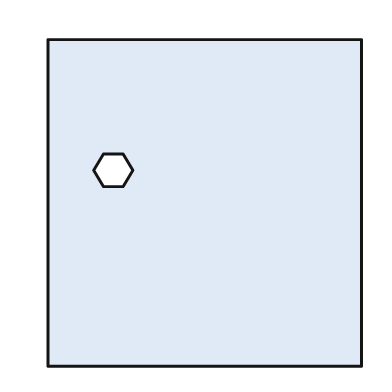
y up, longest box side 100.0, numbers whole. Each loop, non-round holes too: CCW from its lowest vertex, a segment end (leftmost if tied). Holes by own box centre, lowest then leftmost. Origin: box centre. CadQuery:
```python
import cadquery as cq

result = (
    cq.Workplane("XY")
    .moveTo(-48.0, -50.0)
    .lineTo(48.0, -50.0)
    .lineTo(48.0, 50.0)
    .lineTo(-48.0, 50.0)
    .close()
    .moveTo(-31.0, 5.0)
    .lineTo(-25.0, 5.0)
    .lineTo(-22.0, 10.0)
    .lineTo(-25.0, 15.0)
    .lineTo(-31.0, 15.0)
    .lineTo(-34.0, 10.0)
    .close()
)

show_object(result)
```